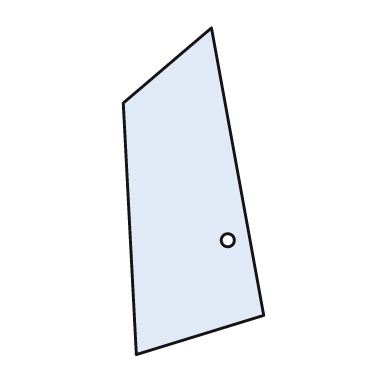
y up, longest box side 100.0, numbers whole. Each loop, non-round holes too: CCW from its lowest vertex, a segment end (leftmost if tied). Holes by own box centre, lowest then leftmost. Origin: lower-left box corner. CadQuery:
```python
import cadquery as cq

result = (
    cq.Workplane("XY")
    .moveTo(4.0, 0.0)
    .lineTo(43.0, 12.0)
    .lineTo(27.0, 100.0)
    .lineTo(0.0, 77.0)
    .close()
    .moveTo(32.0, 35.0)
    .circle(2.0)
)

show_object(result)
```